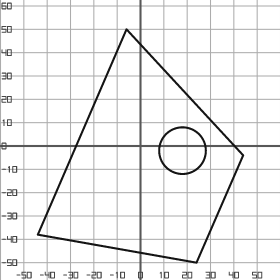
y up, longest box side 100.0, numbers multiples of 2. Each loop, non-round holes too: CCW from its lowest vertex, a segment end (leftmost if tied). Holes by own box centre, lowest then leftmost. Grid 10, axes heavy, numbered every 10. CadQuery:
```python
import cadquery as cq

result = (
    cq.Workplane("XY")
    .moveTo(24.0, -50.0)
    .lineTo(44.0, -4.0)
    .lineTo(-6.0, 50.0)
    .lineTo(-44.0, -38.0)
    .close()
    .moveTo(18.0, -2.0)
    .circle(10.0)
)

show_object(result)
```